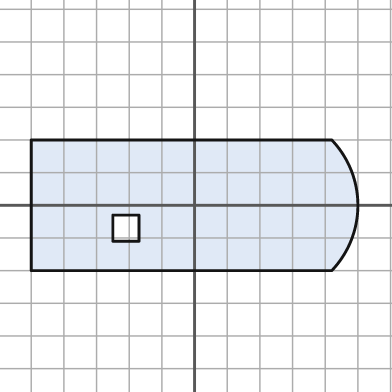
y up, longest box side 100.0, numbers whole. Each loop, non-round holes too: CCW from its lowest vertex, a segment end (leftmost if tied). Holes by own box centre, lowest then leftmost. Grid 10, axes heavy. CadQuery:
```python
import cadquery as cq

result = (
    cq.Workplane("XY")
    .moveTo(-50.0, -20.0)
    .lineTo(42.0, -20.0)
    .threePointArc((50.0, 0.0), (42.0, 20.0))
    .lineTo(-50.0, 20.0)
    .close()
    .moveTo(-25.0, -11.0)
    .lineTo(-17.0, -11.0)
    .lineTo(-17.0, -3.0)
    .lineTo(-25.0, -3.0)
    .close()
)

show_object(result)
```